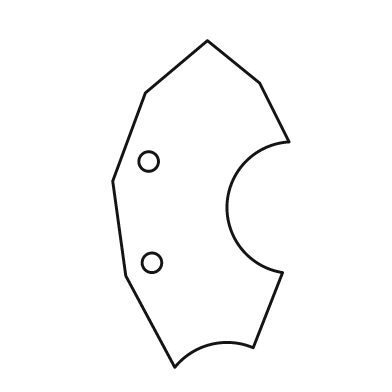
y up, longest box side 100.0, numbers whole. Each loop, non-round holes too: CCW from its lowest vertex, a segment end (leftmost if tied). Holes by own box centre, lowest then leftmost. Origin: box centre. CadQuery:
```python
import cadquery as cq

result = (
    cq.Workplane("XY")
    .moveTo(-8.0, -50.0)
    .threePointArc((3.0, -43.0), (16.0, -44.0))
    .lineTo(25.0, -21.0)
    .threePointArc((8.0, 0.0), (27.0, 19.0))
    .lineTo(18.0, 37.0)
    .lineTo(2.0, 50.0)
    .lineTo(-17.0, 34.0)
    .lineTo(-27.0, 7.0)
    .lineTo(-23.0, -22.0)
    .close()
    .moveTo(-15.0, -18.0)
    .circle(3.0)
    .moveTo(-16.0, 13.0)
    .circle(3.0)
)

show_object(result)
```